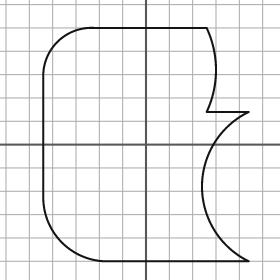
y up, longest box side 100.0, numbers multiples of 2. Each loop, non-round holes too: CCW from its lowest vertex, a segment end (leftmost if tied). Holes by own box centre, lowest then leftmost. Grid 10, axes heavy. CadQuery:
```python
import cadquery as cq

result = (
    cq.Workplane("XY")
    .moveTo(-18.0, -50.0)
    .lineTo(44.0, -50.0)
    .threePointArc((24.0, -18.0), (44.0, 14.0))
    .lineTo(26.0, 14.0)
    .threePointArc((30.0, 32.0), (26.0, 50.0))
    .lineTo(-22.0, 50.0)
    .threePointArc((-38.0, 44.0), (-44.0, 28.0))
    .lineTo(-44.0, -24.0)
    .threePointArc((-36.0, -42.0), (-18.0, -50.0))
    .close()
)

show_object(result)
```